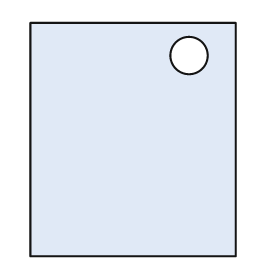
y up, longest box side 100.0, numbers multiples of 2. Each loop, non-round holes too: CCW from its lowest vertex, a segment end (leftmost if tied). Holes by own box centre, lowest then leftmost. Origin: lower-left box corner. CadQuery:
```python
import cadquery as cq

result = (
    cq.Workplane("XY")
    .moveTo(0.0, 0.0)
    .lineTo(88.0, 0.0)
    .lineTo(88.0, 100.0)
    .lineTo(0.0, 100.0)
    .close()
    .moveTo(68.0, 86.0)
    .circle(8.0)
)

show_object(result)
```